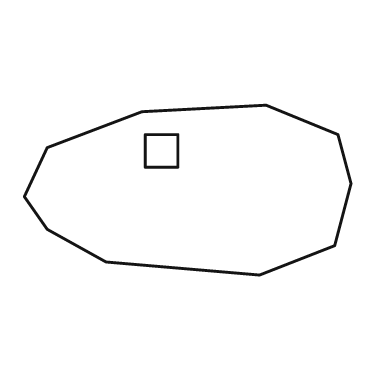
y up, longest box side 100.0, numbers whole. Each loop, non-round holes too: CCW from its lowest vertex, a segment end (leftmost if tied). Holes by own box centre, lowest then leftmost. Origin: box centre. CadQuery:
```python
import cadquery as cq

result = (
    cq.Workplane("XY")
    .moveTo(22.0, -26.0)
    .lineTo(45.0, -17.0)
    .lineTo(50.0, 2.0)
    .lineTo(46.0, 17.0)
    .lineTo(24.0, 26.0)
    .lineTo(-14.0, 24.0)
    .lineTo(-43.0, 13.0)
    .lineTo(-50.0, -2.0)
    .lineTo(-43.0, -12.0)
    .lineTo(-25.0, -22.0)
    .close()
    .moveTo(-13.0, 7.0)
    .lineTo(-3.0, 7.0)
    .lineTo(-3.0, 17.0)
    .lineTo(-13.0, 17.0)
    .close()
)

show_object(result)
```